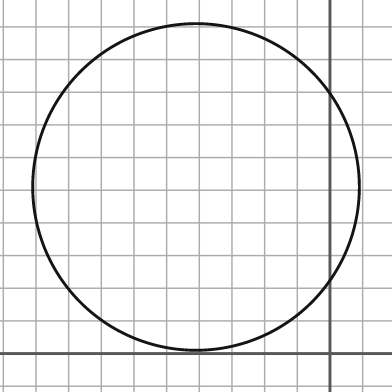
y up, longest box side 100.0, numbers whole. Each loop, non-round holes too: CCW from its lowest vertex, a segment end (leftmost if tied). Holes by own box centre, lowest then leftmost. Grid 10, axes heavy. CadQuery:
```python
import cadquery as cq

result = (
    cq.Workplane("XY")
    .moveTo(-41.0, 51.0)
    .circle(50.0)
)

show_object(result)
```